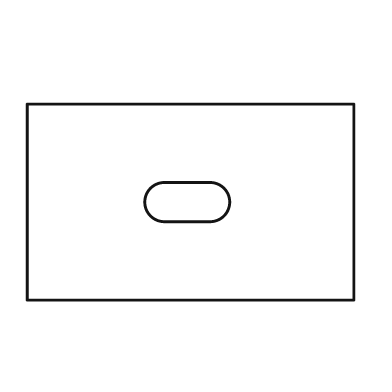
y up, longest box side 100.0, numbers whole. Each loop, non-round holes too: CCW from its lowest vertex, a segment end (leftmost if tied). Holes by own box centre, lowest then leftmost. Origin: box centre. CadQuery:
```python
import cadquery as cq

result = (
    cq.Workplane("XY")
    .moveTo(-50.0, -30.0)
    .lineTo(50.0, -30.0)
    .lineTo(50.0, 30.0)
    .lineTo(-50.0, 30.0)
    .close()
    .moveTo(-8.0, -6.0)
    .lineTo(6.0, -6.0)
    .threePointArc((12.0, 0.0), (6.0, 6.0))
    .lineTo(-8.0, 6.0)
    .threePointArc((-14.0, 0.0), (-8.0, -6.0))
    .close()
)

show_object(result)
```